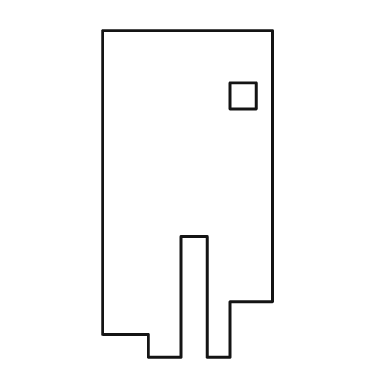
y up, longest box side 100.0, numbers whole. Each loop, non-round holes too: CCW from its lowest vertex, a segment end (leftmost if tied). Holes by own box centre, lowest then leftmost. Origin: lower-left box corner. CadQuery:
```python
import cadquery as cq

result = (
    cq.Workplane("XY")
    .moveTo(14.0, 0.0)
    .lineTo(24.0, 0.0)
    .lineTo(24.0, 37.0)
    .lineTo(32.0, 37.0)
    .lineTo(32.0, 0.0)
    .lineTo(39.0, 0.0)
    .lineTo(39.0, 17.0)
    .lineTo(52.0, 17.0)
    .lineTo(52.0, 100.0)
    .lineTo(0.0, 100.0)
    .lineTo(0.0, 7.0)
    .lineTo(14.0, 7.0)
    .close()
    .moveTo(39.0, 76.0)
    .lineTo(47.0, 76.0)
    .lineTo(47.0, 84.0)
    .lineTo(39.0, 84.0)
    .close()
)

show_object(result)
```